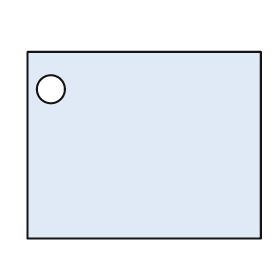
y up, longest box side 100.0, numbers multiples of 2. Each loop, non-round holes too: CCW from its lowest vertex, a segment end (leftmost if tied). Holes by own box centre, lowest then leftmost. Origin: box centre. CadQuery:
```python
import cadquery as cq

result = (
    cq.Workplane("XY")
    .moveTo(-50.0, -40.0)
    .lineTo(50.0, -40.0)
    .lineTo(50.0, 40.0)
    .lineTo(-50.0, 40.0)
    .close()
    .moveTo(-40.0, 24.0)
    .circle(6.0)
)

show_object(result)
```